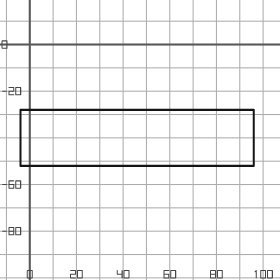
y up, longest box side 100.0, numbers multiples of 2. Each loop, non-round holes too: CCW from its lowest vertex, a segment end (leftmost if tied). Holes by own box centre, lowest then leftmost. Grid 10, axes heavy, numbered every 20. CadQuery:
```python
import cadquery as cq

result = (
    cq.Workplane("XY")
    .moveTo(-4.0, -52.0)
    .lineTo(96.0, -52.0)
    .lineTo(96.0, -28.0)
    .lineTo(-4.0, -28.0)
    .close()
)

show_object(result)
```